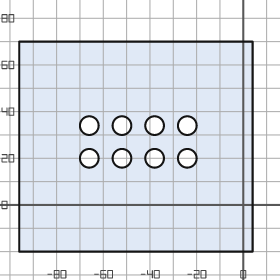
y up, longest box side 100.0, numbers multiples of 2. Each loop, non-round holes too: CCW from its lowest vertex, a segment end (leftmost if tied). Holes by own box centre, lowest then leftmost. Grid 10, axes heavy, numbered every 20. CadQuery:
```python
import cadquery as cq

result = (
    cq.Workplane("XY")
    .moveTo(-96.0, -20.0)
    .lineTo(4.0, -20.0)
    .lineTo(4.0, 70.0)
    .lineTo(-96.0, 70.0)
    .close()
    .moveTo(-66.0, 20.0)
    .circle(4.0)
    .moveTo(-52.0, 20.0)
    .circle(4.0)
    .moveTo(-38.0, 20.0)
    .circle(4.0)
    .moveTo(-24.0, 20.0)
    .circle(4.0)
    .moveTo(-66.0, 34.0)
    .circle(4.0)
    .moveTo(-52.0, 34.0)
    .circle(4.0)
    .moveTo(-38.0, 34.0)
    .circle(4.0)
    .moveTo(-24.0, 34.0)
    .circle(4.0)
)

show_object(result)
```